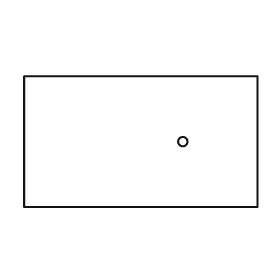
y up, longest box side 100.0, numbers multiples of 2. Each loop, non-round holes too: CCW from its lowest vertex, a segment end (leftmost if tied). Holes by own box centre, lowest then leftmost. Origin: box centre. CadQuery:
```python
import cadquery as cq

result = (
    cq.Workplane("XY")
    .moveTo(-50.0, -28.0)
    .lineTo(50.0, -28.0)
    .lineTo(50.0, 28.0)
    .lineTo(-50.0, 28.0)
    .close()
    .moveTo(18.0, 0.0)
    .circle(2.0)
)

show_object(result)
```